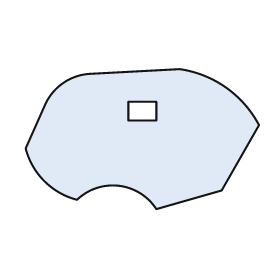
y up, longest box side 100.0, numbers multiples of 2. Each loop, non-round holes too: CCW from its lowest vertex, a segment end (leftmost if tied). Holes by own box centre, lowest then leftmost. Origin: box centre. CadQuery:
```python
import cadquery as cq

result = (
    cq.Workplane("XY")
    .moveTo(6.0, -30.0)
    .lineTo(34.0, -22.0)
    .lineTo(50.0, 6.0)
    .threePointArc((36.0, 22.0), (16.0, 30.0))
    .lineTo(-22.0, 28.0)
    .threePointArc((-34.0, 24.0), (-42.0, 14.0))
    .lineTo(-50.0, -4.0)
    .threePointArc((-42.0, -18.0), (-28.0, -26.0))
    .threePointArc((-10.0, -20.0), (6.0, -30.0))
    .close()
    .moveTo(-6.0, 8.0)
    .lineTo(6.0, 8.0)
    .lineTo(6.0, 16.0)
    .lineTo(-6.0, 16.0)
    .close()
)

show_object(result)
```